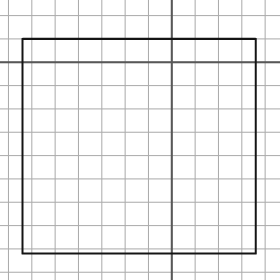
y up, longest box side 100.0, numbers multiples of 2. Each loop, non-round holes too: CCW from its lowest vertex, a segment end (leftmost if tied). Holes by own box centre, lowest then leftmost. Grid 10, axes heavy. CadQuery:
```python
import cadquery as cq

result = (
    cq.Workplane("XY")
    .moveTo(-64.0, -82.0)
    .lineTo(36.0, -82.0)
    .lineTo(36.0, 10.0)
    .lineTo(-64.0, 10.0)
    .close()
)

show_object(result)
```